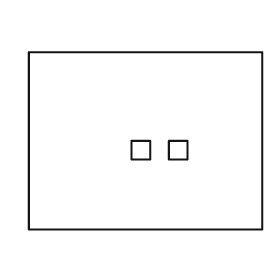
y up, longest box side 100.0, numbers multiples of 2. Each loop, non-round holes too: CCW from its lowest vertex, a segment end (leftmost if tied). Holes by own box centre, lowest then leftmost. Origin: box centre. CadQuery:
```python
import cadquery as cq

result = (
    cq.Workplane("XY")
    .moveTo(-50.0, -38.0)
    .lineTo(50.0, -38.0)
    .lineTo(50.0, 38.0)
    .lineTo(-50.0, 38.0)
    .close()
    .moveTo(-6.0, -8.0)
    .lineTo(2.0, -8.0)
    .lineTo(2.0, 0.0)
    .lineTo(-6.0, 0.0)
    .close()
    .moveTo(10.0, -8.0)
    .lineTo(18.0, -8.0)
    .lineTo(18.0, 0.0)
    .lineTo(10.0, 0.0)
    .close()
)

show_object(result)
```